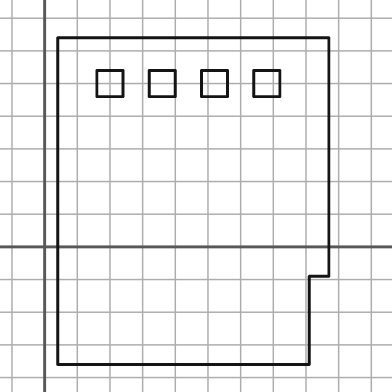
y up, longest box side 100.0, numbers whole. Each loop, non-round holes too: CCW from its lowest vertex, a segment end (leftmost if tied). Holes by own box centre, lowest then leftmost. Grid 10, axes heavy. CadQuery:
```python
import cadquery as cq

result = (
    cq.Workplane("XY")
    .moveTo(4.0, -36.0)
    .lineTo(81.0, -36.0)
    .lineTo(81.0, -9.0)
    .lineTo(87.0, -9.0)
    .lineTo(87.0, 64.0)
    .lineTo(4.0, 64.0)
    .close()
    .moveTo(16.0, 46.0)
    .lineTo(24.0, 46.0)
    .lineTo(24.0, 54.0)
    .lineTo(16.0, 54.0)
    .close()
    .moveTo(32.0, 46.0)
    .lineTo(40.0, 46.0)
    .lineTo(40.0, 54.0)
    .lineTo(32.0, 54.0)
    .close()
    .moveTo(48.0, 46.0)
    .lineTo(56.0, 46.0)
    .lineTo(56.0, 54.0)
    .lineTo(48.0, 54.0)
    .close()
    .moveTo(64.0, 46.0)
    .lineTo(72.0, 46.0)
    .lineTo(72.0, 54.0)
    .lineTo(64.0, 54.0)
    .close()
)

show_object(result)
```